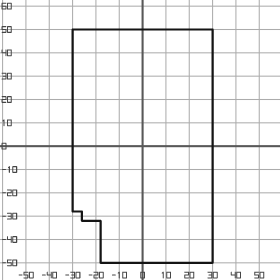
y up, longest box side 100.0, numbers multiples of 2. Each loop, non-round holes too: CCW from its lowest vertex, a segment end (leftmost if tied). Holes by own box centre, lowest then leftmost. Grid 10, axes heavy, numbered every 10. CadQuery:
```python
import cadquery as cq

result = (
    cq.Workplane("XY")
    .moveTo(-18.0, -50.0)
    .lineTo(30.0, -50.0)
    .lineTo(30.0, 50.0)
    .lineTo(-30.0, 50.0)
    .lineTo(-30.0, -28.0)
    .lineTo(-26.0, -28.0)
    .lineTo(-26.0, -32.0)
    .lineTo(-18.0, -32.0)
    .close()
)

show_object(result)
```